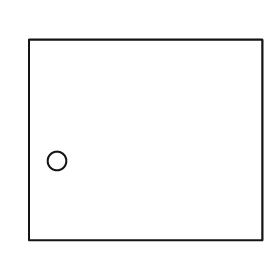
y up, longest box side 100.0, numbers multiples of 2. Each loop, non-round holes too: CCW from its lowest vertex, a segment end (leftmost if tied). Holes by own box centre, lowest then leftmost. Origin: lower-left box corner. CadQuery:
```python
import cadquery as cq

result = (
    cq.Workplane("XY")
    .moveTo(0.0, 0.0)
    .lineTo(100.0, 0.0)
    .lineTo(100.0, 86.0)
    .lineTo(0.0, 86.0)
    .close()
    .moveTo(12.0, 34.0)
    .circle(4.0)
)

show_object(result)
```